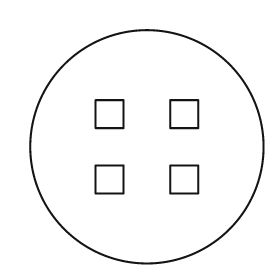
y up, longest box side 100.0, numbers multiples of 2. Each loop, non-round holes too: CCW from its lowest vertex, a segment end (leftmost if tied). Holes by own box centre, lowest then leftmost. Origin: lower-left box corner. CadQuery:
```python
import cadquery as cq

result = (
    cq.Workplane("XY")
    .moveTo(50.0, 50.0)
    .circle(50.0)
    .moveTo(28.0, 30.0)
    .lineTo(40.0, 30.0)
    .lineTo(40.0, 42.0)
    .lineTo(28.0, 42.0)
    .close()
    .moveTo(60.0, 30.0)
    .lineTo(72.0, 30.0)
    .lineTo(72.0, 42.0)
    .lineTo(60.0, 42.0)
    .close()
    .moveTo(28.0, 58.0)
    .lineTo(40.0, 58.0)
    .lineTo(40.0, 70.0)
    .lineTo(28.0, 70.0)
    .close()
    .moveTo(60.0, 58.0)
    .lineTo(72.0, 58.0)
    .lineTo(72.0, 70.0)
    .lineTo(60.0, 70.0)
    .close()
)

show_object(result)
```